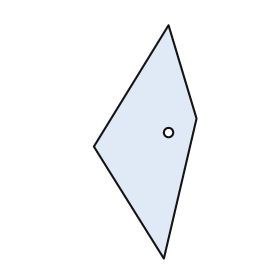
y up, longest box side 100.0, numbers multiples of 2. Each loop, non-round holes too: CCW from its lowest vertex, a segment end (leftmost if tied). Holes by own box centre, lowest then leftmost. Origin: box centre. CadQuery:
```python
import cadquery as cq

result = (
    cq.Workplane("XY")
    .moveTo(8.0, -50.0)
    .lineTo(22.0, 10.0)
    .lineTo(10.0, 50.0)
    .lineTo(-22.0, -2.0)
    .close()
    .moveTo(10.0, 4.0)
    .circle(2.0)
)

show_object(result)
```